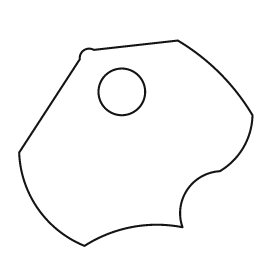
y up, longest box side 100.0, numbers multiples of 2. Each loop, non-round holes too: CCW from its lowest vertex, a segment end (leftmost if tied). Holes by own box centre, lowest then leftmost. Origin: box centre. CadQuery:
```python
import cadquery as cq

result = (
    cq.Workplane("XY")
    .moveTo(-22.0, -44.0)
    .threePointArc((-2.0, -36.0), (20.0, -36.0))
    .threePointArc((22.0, -20.0), (36.0, -12.0))
    .threePointArc((46.0, -2.0), (50.0, 12.0))
    .threePointArc((36.0, 30.0), (18.0, 44.0))
    .lineTo(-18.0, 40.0)
    .threePointArc((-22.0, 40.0), (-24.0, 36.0))
    .lineTo(-50.0, -4.0)
    .threePointArc((-42.0, -28.0), (-22.0, -44.0))
    .close()
    .moveTo(-6.0, 22.0)
    .circle(10.0)
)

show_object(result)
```